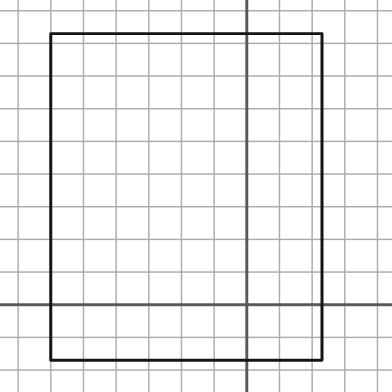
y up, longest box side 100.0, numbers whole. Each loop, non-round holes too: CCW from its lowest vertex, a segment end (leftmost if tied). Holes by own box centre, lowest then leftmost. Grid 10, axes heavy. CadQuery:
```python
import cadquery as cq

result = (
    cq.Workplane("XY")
    .moveTo(-60.0, -17.0)
    .lineTo(23.0, -17.0)
    .lineTo(23.0, 83.0)
    .lineTo(-60.0, 83.0)
    .close()
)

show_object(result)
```